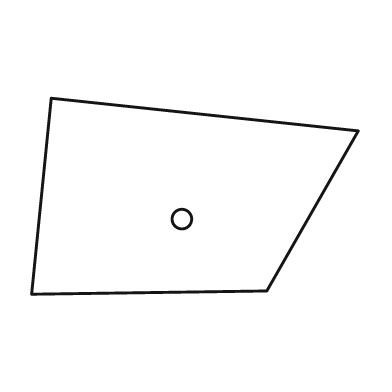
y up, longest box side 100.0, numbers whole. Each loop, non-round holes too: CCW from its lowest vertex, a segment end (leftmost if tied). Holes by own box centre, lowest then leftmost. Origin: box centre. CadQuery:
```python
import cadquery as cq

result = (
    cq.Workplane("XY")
    .moveTo(-50.0, -30.0)
    .lineTo(22.0, -29.0)
    .lineTo(50.0, 20.0)
    .lineTo(-44.0, 30.0)
    .close()
    .moveTo(-4.0, -7.0)
    .circle(3.0)
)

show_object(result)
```